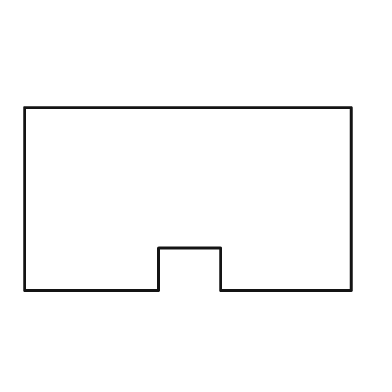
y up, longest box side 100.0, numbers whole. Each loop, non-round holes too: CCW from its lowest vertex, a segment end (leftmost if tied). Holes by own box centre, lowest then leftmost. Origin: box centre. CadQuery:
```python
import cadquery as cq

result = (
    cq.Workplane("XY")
    .moveTo(-50.0, -28.0)
    .lineTo(-9.0, -28.0)
    .lineTo(-9.0, -15.0)
    .lineTo(10.0, -15.0)
    .lineTo(10.0, -28.0)
    .lineTo(50.0, -28.0)
    .lineTo(50.0, 28.0)
    .lineTo(-50.0, 28.0)
    .close()
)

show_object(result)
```